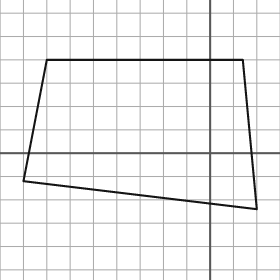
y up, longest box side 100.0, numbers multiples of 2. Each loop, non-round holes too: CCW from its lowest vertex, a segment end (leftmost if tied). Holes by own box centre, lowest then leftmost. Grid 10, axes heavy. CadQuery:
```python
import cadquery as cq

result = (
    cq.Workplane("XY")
    .moveTo(20.0, -24.0)
    .lineTo(14.0, 40.0)
    .lineTo(-70.0, 40.0)
    .lineTo(-80.0, -12.0)
    .close()
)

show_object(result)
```